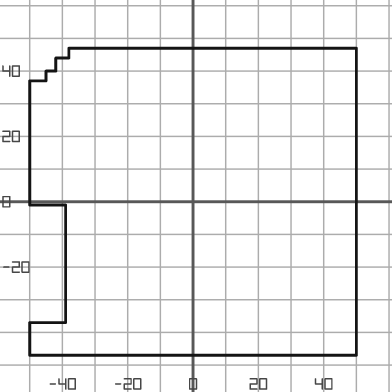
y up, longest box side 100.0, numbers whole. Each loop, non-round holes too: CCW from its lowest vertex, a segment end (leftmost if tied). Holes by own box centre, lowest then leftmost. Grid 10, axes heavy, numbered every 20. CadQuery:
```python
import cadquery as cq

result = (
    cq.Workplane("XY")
    .moveTo(-50.0, -47.0)
    .lineTo(50.0, -47.0)
    .lineTo(50.0, 47.0)
    .lineTo(-38.0, 47.0)
    .lineTo(-38.0, 44.0)
    .lineTo(-42.0, 44.0)
    .lineTo(-42.0, 40.0)
    .lineTo(-45.0, 40.0)
    .lineTo(-45.0, 37.0)
    .lineTo(-50.0, 37.0)
    .lineTo(-50.0, -1.0)
    .lineTo(-39.0, -1.0)
    .lineTo(-39.0, -37.0)
    .lineTo(-50.0, -37.0)
    .close()
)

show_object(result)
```